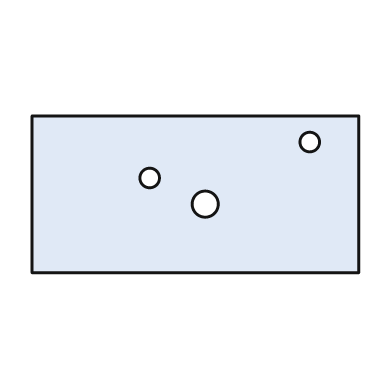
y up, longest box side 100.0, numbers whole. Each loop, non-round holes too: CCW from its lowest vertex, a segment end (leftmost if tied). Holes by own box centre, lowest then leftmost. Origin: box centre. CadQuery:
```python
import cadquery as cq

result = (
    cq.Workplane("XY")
    .moveTo(-50.0, -24.0)
    .lineTo(50.0, -24.0)
    .lineTo(50.0, 24.0)
    .lineTo(-50.0, 24.0)
    .close()
    .moveTo(3.0, -3.0)
    .circle(4.0)
    .moveTo(-14.0, 5.0)
    .circle(3.0)
    .moveTo(35.0, 16.0)
    .circle(3.0)
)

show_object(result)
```